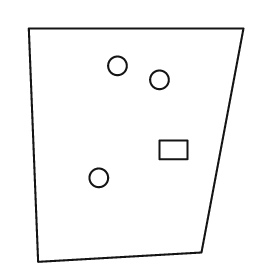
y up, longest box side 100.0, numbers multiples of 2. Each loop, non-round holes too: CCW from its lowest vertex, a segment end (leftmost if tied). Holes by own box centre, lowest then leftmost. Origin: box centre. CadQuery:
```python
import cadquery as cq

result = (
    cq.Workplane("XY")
    .moveTo(-42.0, -50.0)
    .lineTo(28.0, -46.0)
    .lineTo(46.0, 50.0)
    .lineTo(-46.0, 50.0)
    .close()
    .moveTo(-16.0, -14.0)
    .circle(4.0)
    .moveTo(10.0, -6.0)
    .lineTo(22.0, -6.0)
    .lineTo(22.0, 2.0)
    .lineTo(10.0, 2.0)
    .close()
    .moveTo(10.0, 28.0)
    .circle(4.0)
    .moveTo(-8.0, 34.0)
    .circle(4.0)
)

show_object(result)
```